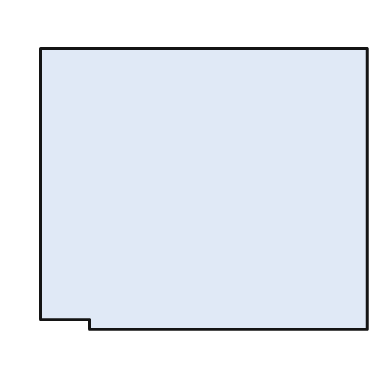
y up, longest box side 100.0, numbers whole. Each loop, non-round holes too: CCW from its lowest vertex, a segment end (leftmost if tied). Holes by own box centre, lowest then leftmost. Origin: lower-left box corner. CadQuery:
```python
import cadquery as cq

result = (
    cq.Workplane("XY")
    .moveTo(15.0, 0.0)
    .lineTo(100.0, 0.0)
    .lineTo(100.0, 86.0)
    .lineTo(0.0, 86.0)
    .lineTo(0.0, 3.0)
    .lineTo(15.0, 3.0)
    .close()
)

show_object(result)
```